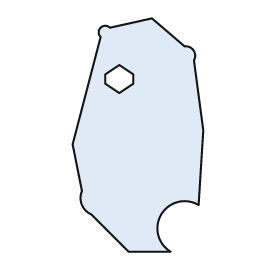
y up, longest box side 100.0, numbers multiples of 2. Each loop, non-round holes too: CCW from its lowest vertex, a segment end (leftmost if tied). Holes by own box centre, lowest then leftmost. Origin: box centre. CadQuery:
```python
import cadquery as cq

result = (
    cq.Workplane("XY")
    .moveTo(-4.0, -50.0)
    .lineTo(14.0, -50.0)
    .threePointArc((10.0, -34.0), (26.0, -30.0))
    .lineTo(28.0, 2.0)
    .lineTo(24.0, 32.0)
    .threePointArc((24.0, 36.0), (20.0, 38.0))
    .lineTo(6.0, 50.0)
    .lineTo(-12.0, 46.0)
    .threePointArc((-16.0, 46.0), (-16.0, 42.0))
    .lineTo(-28.0, -4.0)
    .lineTo(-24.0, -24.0)
    .threePointArc((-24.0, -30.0), (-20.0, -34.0))
    .close()
    .moveTo(-8.0, 18.0)
    .lineTo(-2.0, 22.0)
    .lineTo(-2.0, 26.0)
    .lineTo(-8.0, 30.0)
    .lineTo(-14.0, 26.0)
    .lineTo(-14.0, 22.0)
    .close()
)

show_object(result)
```